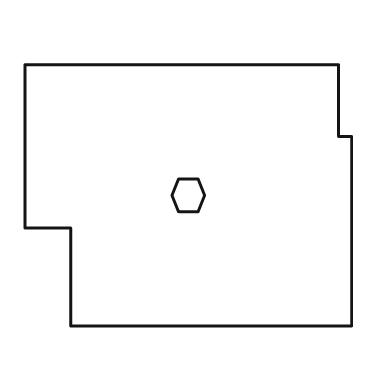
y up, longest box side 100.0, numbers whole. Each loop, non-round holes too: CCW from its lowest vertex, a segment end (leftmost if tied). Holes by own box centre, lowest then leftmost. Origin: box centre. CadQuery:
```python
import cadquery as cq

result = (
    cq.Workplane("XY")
    .moveTo(-36.0, -40.0)
    .lineTo(50.0, -40.0)
    .lineTo(50.0, 18.0)
    .lineTo(46.0, 18.0)
    .lineTo(46.0, 40.0)
    .lineTo(-50.0, 40.0)
    .lineTo(-50.0, -10.0)
    .lineTo(-36.0, -10.0)
    .close()
    .moveTo(-3.0, -5.0)
    .lineTo(3.0, -5.0)
    .lineTo(5.0, 0.0)
    .lineTo(3.0, 5.0)
    .lineTo(-3.0, 5.0)
    .lineTo(-5.0, 0.0)
    .close()
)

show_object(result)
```